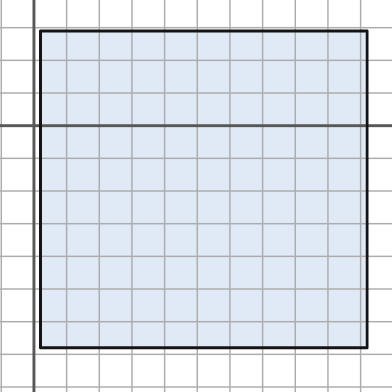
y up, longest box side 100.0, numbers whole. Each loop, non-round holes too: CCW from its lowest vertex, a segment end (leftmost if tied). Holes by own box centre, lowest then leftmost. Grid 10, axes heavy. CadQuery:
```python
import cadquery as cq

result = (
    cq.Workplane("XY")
    .moveTo(2.0, -68.0)
    .lineTo(102.0, -68.0)
    .lineTo(102.0, 29.0)
    .lineTo(2.0, 29.0)
    .close()
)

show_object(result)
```